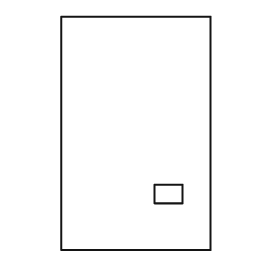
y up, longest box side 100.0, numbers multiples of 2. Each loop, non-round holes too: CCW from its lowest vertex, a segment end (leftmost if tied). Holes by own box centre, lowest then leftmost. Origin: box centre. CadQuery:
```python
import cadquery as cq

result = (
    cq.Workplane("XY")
    .moveTo(-32.0, -50.0)
    .lineTo(32.0, -50.0)
    .lineTo(32.0, 50.0)
    .lineTo(-32.0, 50.0)
    .close()
    .moveTo(8.0, -30.0)
    .lineTo(20.0, -30.0)
    .lineTo(20.0, -22.0)
    .lineTo(8.0, -22.0)
    .close()
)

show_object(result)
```